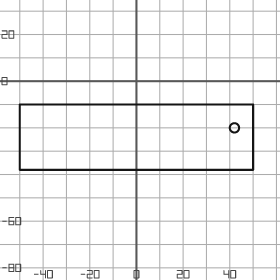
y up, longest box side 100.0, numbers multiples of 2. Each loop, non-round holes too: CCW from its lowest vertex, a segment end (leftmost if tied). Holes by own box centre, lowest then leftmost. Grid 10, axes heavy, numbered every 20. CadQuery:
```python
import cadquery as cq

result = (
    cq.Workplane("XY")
    .moveTo(-50.0, -38.0)
    .lineTo(50.0, -38.0)
    .lineTo(50.0, -10.0)
    .lineTo(-50.0, -10.0)
    .close()
    .moveTo(42.0, -20.0)
    .circle(2.0)
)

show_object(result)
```